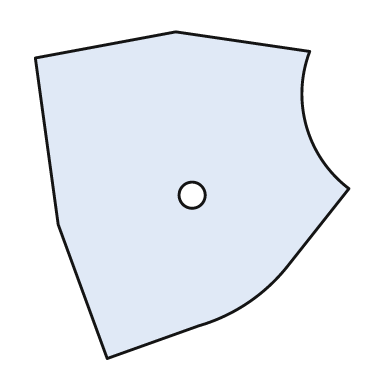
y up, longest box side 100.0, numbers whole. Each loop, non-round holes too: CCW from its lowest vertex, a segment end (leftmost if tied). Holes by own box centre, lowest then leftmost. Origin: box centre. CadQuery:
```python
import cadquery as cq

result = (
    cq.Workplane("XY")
    .moveTo(-26.0, -50.0)
    .lineTo(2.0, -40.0)
    .threePointArc((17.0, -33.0), (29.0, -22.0))
    .lineTo(48.0, 2.0)
    .threePointArc((35.0, 21.0), (36.0, 44.0))
    .lineTo(-5.0, 50.0)
    .lineTo(-48.0, 42.0)
    .lineTo(-41.0, -9.0)
    .close()
    .moveTo(0.0, 0.0)
    .circle(4.0)
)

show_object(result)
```